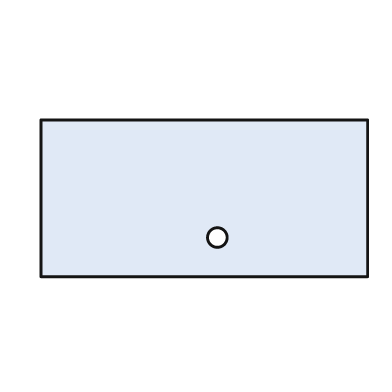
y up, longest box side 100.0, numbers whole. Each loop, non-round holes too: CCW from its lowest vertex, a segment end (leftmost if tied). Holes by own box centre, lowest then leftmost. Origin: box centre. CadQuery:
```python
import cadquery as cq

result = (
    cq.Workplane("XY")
    .moveTo(-50.0, -24.0)
    .lineTo(50.0, -24.0)
    .lineTo(50.0, 24.0)
    .lineTo(-50.0, 24.0)
    .close()
    .moveTo(4.0, -12.0)
    .circle(3.0)
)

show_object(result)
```